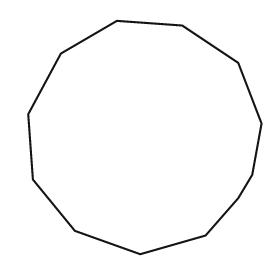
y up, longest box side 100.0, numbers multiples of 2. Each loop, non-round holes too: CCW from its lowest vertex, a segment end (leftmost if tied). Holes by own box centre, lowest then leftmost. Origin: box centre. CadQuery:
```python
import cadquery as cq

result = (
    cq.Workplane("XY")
    .moveTo(-2.0, -50.0)
    .lineTo(26.0, -42.0)
    .lineTo(40.0, -26.0)
    .lineTo(46.0, -16.0)
    .lineTo(50.0, 6.0)
    .lineTo(40.0, 32.0)
    .lineTo(16.0, 48.0)
    .lineTo(-12.0, 50.0)
    .lineTo(-36.0, 36.0)
    .lineTo(-50.0, 10.0)
    .lineTo(-48.0, -18.0)
    .lineTo(-30.0, -40.0)
    .close()
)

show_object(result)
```